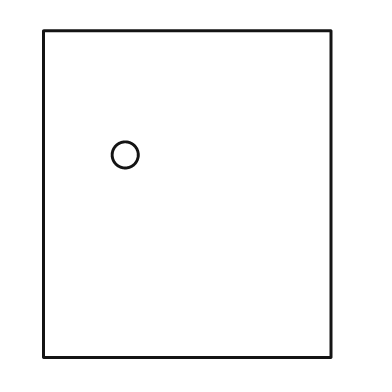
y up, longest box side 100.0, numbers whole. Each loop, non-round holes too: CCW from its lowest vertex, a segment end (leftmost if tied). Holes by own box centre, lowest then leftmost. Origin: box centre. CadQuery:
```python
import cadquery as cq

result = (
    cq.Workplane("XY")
    .moveTo(-44.0, -50.0)
    .lineTo(44.0, -50.0)
    .lineTo(44.0, 50.0)
    .lineTo(-44.0, 50.0)
    .close()
    .moveTo(-19.0, 12.0)
    .circle(4.0)
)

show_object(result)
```